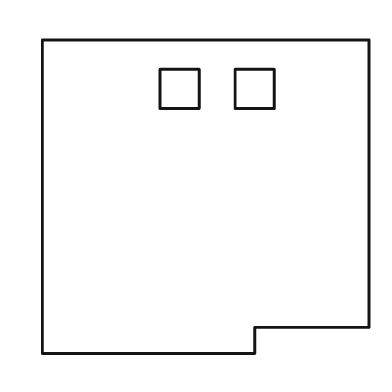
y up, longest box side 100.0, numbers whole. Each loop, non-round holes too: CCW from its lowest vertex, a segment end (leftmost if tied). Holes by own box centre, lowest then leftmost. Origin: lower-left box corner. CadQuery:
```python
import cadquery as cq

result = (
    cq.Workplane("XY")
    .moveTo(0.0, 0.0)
    .lineTo(65.0, 0.0)
    .lineTo(65.0, 8.0)
    .lineTo(100.0, 8.0)
    .lineTo(100.0, 96.0)
    .lineTo(0.0, 96.0)
    .close()
    .moveTo(36.0, 75.0)
    .lineTo(48.0, 75.0)
    .lineTo(48.0, 87.0)
    .lineTo(36.0, 87.0)
    .close()
    .moveTo(59.0, 75.0)
    .lineTo(71.0, 75.0)
    .lineTo(71.0, 87.0)
    .lineTo(59.0, 87.0)
    .close()
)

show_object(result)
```